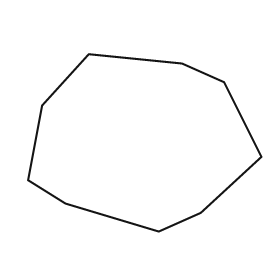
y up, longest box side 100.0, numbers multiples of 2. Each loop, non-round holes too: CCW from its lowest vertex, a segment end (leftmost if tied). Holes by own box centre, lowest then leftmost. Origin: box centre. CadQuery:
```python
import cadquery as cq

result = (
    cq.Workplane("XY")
    .moveTo(6.0, -38.0)
    .lineTo(24.0, -30.0)
    .lineTo(50.0, -6.0)
    .lineTo(34.0, 26.0)
    .lineTo(16.0, 34.0)
    .lineTo(-24.0, 38.0)
    .lineTo(-44.0, 16.0)
    .lineTo(-50.0, -16.0)
    .lineTo(-34.0, -26.0)
    .close()
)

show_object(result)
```